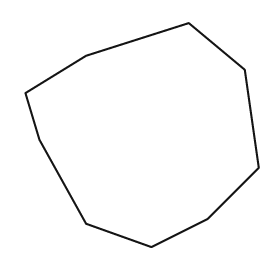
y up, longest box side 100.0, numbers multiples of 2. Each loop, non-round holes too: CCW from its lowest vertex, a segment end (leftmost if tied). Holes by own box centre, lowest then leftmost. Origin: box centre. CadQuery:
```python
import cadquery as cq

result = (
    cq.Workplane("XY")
    .moveTo(4.0, -48.0)
    .lineTo(28.0, -36.0)
    .lineTo(50.0, -14.0)
    .lineTo(44.0, 28.0)
    .lineTo(20.0, 48.0)
    .lineTo(-24.0, 34.0)
    .lineTo(-50.0, 18.0)
    .lineTo(-44.0, -2.0)
    .lineTo(-24.0, -38.0)
    .close()
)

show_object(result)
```